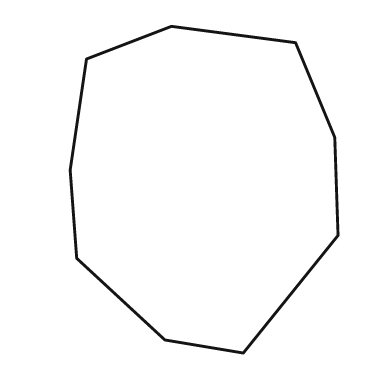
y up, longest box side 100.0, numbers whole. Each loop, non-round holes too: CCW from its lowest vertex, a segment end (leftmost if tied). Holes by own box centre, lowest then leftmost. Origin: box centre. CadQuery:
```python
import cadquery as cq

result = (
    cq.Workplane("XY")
    .moveTo(12.0, -50.0)
    .lineTo(41.0, -14.0)
    .lineTo(40.0, 16.0)
    .lineTo(28.0, 45.0)
    .lineTo(-10.0, 50.0)
    .lineTo(-36.0, 40.0)
    .lineTo(-41.0, 6.0)
    .lineTo(-39.0, -21.0)
    .lineTo(-12.0, -46.0)
    .close()
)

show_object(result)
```